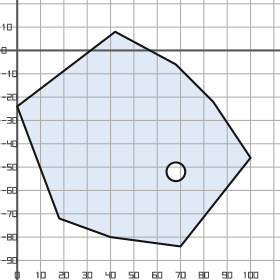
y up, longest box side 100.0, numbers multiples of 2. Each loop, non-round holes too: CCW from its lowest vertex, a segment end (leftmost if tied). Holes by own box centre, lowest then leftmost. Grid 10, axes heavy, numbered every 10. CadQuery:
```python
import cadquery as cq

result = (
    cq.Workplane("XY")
    .moveTo(70.0, -84.0)
    .lineTo(100.0, -46.0)
    .lineTo(84.0, -22.0)
    .lineTo(68.0, -6.0)
    .lineTo(42.0, 8.0)
    .lineTo(0.0, -24.0)
    .lineTo(18.0, -72.0)
    .lineTo(40.0, -80.0)
    .close()
    .moveTo(68.0, -52.0)
    .circle(4.0)
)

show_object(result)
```